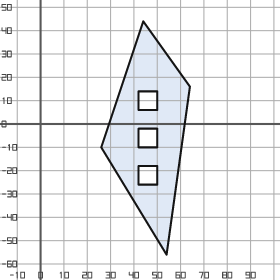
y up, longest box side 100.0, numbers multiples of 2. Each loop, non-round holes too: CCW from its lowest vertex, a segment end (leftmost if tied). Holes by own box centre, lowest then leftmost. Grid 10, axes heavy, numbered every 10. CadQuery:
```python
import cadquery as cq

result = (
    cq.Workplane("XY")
    .moveTo(54.0, -56.0)
    .lineTo(64.0, 16.0)
    .lineTo(44.0, 44.0)
    .lineTo(26.0, -10.0)
    .close()
    .moveTo(42.0, -26.0)
    .lineTo(50.0, -26.0)
    .lineTo(50.0, -18.0)
    .lineTo(42.0, -18.0)
    .close()
    .moveTo(42.0, -10.0)
    .lineTo(50.0, -10.0)
    .lineTo(50.0, -2.0)
    .lineTo(42.0, -2.0)
    .close()
    .moveTo(42.0, 6.0)
    .lineTo(50.0, 6.0)
    .lineTo(50.0, 14.0)
    .lineTo(42.0, 14.0)
    .close()
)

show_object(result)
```